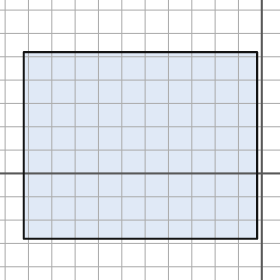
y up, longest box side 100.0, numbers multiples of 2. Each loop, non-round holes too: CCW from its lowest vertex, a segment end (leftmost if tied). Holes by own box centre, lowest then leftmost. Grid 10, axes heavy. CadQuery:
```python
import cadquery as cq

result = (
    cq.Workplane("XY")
    .moveTo(-102.0, -28.0)
    .lineTo(-2.0, -28.0)
    .lineTo(-2.0, 52.0)
    .lineTo(-102.0, 52.0)
    .close()
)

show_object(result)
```